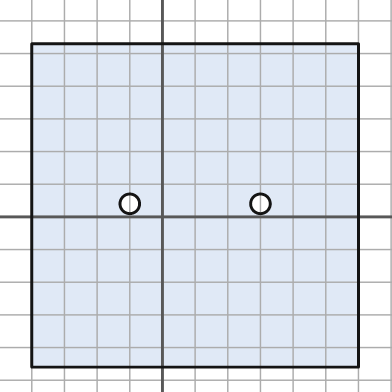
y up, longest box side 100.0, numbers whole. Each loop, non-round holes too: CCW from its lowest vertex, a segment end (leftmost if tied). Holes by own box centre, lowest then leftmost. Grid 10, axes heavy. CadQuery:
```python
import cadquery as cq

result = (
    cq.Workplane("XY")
    .moveTo(-40.0, -46.0)
    .lineTo(60.0, -46.0)
    .lineTo(60.0, 53.0)
    .lineTo(-40.0, 53.0)
    .close()
    .moveTo(-10.0, 4.0)
    .circle(3.0)
    .moveTo(30.0, 4.0)
    .circle(3.0)
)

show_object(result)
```